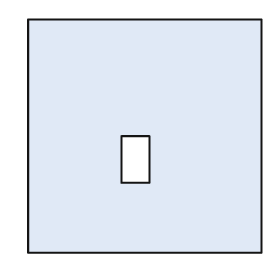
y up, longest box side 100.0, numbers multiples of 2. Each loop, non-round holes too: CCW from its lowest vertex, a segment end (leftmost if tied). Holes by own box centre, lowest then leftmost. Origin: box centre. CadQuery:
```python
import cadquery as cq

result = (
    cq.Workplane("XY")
    .moveTo(-50.0, -50.0)
    .lineTo(50.0, -50.0)
    .lineTo(50.0, 50.0)
    .lineTo(-50.0, 50.0)
    .close()
    .moveTo(-10.0, -20.0)
    .lineTo(2.0, -20.0)
    .lineTo(2.0, 0.0)
    .lineTo(-10.0, 0.0)
    .close()
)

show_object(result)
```